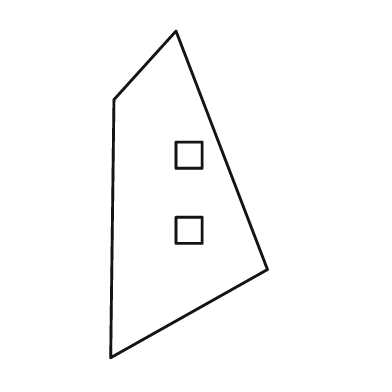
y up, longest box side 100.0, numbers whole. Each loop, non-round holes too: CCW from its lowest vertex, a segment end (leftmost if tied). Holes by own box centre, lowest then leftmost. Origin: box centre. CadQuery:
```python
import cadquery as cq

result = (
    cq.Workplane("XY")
    .moveTo(-24.0, -50.0)
    .lineTo(24.0, -23.0)
    .lineTo(-4.0, 50.0)
    .lineTo(-23.0, 29.0)
    .close()
    .moveTo(-4.0, -15.0)
    .lineTo(4.0, -15.0)
    .lineTo(4.0, -7.0)
    .lineTo(-4.0, -7.0)
    .close()
    .moveTo(-4.0, 8.0)
    .lineTo(4.0, 8.0)
    .lineTo(4.0, 16.0)
    .lineTo(-4.0, 16.0)
    .close()
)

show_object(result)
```